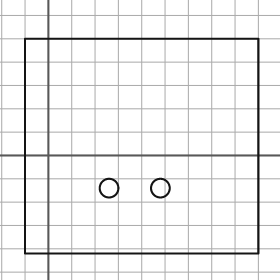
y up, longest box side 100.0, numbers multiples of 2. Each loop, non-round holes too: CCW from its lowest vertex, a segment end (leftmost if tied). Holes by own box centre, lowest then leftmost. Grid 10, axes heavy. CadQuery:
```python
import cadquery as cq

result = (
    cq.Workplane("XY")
    .moveTo(-10.0, -42.0)
    .lineTo(90.0, -42.0)
    .lineTo(90.0, 50.0)
    .lineTo(-10.0, 50.0)
    .close()
    .moveTo(26.0, -14.0)
    .circle(4.0)
    .moveTo(48.0, -14.0)
    .circle(4.0)
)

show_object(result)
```